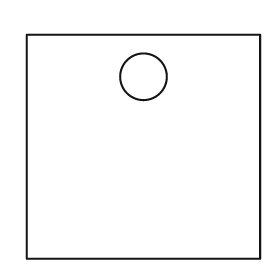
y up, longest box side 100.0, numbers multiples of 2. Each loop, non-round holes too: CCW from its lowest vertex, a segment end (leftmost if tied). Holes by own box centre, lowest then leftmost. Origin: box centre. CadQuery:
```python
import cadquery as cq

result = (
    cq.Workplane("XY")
    .moveTo(-50.0, -48.0)
    .lineTo(50.0, -48.0)
    .lineTo(50.0, 48.0)
    .lineTo(-50.0, 48.0)
    .close()
    .moveTo(0.0, 30.0)
    .circle(10.0)
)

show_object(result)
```